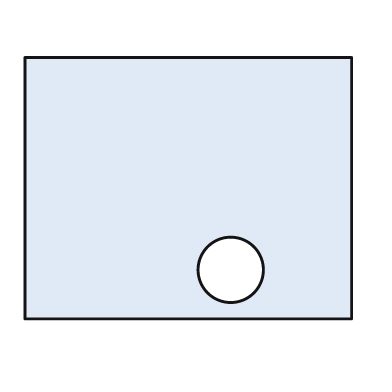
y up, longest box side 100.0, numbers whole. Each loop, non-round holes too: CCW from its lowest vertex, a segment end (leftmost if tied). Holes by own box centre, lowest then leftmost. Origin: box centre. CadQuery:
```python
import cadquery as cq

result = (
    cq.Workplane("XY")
    .moveTo(-50.0, -40.0)
    .lineTo(50.0, -40.0)
    .lineTo(50.0, 40.0)
    .lineTo(-50.0, 40.0)
    .close()
    .moveTo(13.0, -25.0)
    .circle(10.0)
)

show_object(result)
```